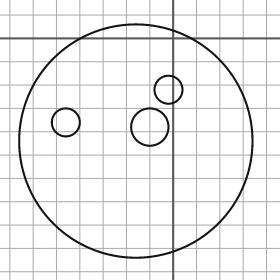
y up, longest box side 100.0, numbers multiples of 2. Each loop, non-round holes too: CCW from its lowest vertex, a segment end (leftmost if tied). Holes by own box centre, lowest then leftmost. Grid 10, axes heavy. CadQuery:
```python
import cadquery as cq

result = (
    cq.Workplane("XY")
    .moveTo(-16.0, -44.0)
    .circle(50.0)
    .moveTo(-10.0, -38.0)
    .circle(8.0)
    .moveTo(-46.0, -36.0)
    .circle(6.0)
    .moveTo(-2.0, -22.0)
    .circle(6.0)
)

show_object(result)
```